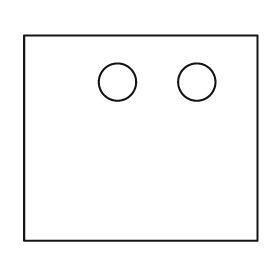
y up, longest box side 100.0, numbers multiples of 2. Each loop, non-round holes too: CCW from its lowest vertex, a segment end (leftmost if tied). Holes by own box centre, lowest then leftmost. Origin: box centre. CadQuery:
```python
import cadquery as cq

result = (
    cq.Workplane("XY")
    .moveTo(-50.0, -44.0)
    .lineTo(50.0, -44.0)
    .lineTo(50.0, 44.0)
    .lineTo(-50.0, 44.0)
    .close()
    .moveTo(-10.0, 24.0)
    .circle(8.0)
    .moveTo(24.0, 24.0)
    .circle(8.0)
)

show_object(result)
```